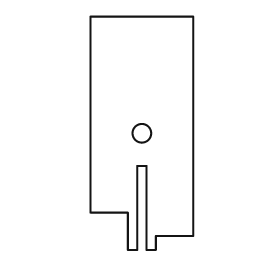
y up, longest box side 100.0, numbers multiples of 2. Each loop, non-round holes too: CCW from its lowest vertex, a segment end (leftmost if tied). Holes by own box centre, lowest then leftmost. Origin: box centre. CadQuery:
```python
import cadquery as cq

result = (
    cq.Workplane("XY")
    .moveTo(-6.0, -50.0)
    .lineTo(-2.0, -50.0)
    .lineTo(-2.0, -14.0)
    .lineTo(2.0, -14.0)
    .lineTo(2.0, -50.0)
    .lineTo(6.0, -50.0)
    .lineTo(6.0, -44.0)
    .lineTo(22.0, -44.0)
    .lineTo(22.0, 50.0)
    .lineTo(-22.0, 50.0)
    .lineTo(-22.0, -34.0)
    .lineTo(-6.0, -34.0)
    .close()
    .moveTo(0.0, 0.0)
    .circle(4.0)
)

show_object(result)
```